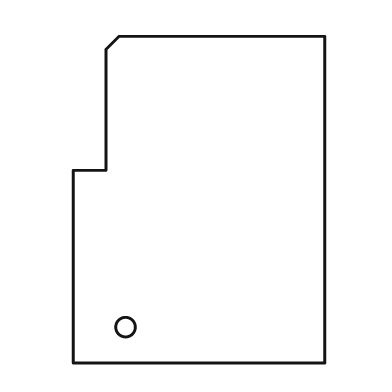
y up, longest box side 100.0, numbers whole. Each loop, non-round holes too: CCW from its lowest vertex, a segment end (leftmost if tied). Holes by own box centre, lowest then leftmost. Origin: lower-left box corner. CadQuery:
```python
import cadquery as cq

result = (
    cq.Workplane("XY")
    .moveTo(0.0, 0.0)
    .lineTo(77.0, 0.0)
    .lineTo(77.0, 100.0)
    .lineTo(14.0, 100.0)
    .lineTo(10.0, 96.0)
    .lineTo(10.0, 59.0)
    .lineTo(0.0, 59.0)
    .close()
    .moveTo(16.0, 11.0)
    .circle(3.0)
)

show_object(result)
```